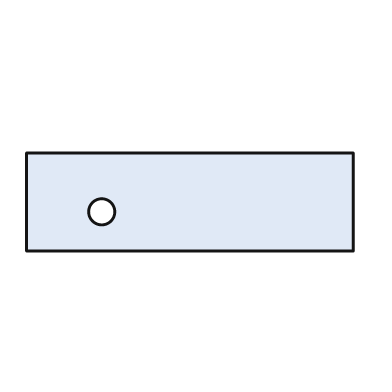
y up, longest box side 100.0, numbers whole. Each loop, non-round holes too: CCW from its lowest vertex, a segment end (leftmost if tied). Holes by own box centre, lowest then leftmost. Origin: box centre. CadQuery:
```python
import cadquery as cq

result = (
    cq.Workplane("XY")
    .moveTo(-50.0, -15.0)
    .lineTo(50.0, -15.0)
    .lineTo(50.0, 15.0)
    .lineTo(-50.0, 15.0)
    .close()
    .moveTo(-27.0, -3.0)
    .circle(4.0)
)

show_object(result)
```